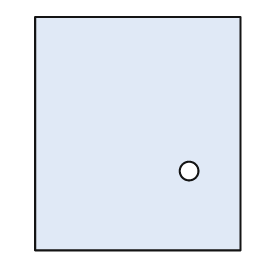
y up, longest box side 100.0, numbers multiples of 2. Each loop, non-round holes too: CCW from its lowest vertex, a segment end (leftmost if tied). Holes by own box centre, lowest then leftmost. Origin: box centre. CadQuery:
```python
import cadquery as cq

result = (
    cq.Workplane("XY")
    .moveTo(-44.0, -50.0)
    .lineTo(44.0, -50.0)
    .lineTo(44.0, 50.0)
    .lineTo(-44.0, 50.0)
    .close()
    .moveTo(22.0, -16.0)
    .circle(4.0)
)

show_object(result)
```